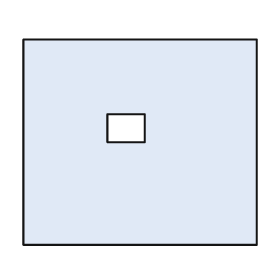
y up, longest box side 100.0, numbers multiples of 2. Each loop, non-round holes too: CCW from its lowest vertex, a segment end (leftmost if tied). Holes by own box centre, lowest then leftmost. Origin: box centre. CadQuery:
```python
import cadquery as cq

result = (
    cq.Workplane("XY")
    .moveTo(-50.0, -44.0)
    .lineTo(50.0, -44.0)
    .lineTo(50.0, 44.0)
    .lineTo(-50.0, 44.0)
    .close()
    .moveTo(-14.0, 0.0)
    .lineTo(2.0, 0.0)
    .lineTo(2.0, 12.0)
    .lineTo(-14.0, 12.0)
    .close()
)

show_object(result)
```